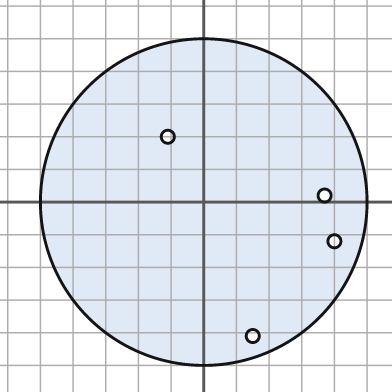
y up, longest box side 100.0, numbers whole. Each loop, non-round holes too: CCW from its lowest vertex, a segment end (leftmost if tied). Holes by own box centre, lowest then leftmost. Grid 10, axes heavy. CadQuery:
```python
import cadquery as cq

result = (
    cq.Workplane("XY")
    .moveTo(0.0, 0.0)
    .circle(50.0)
    .moveTo(15.0, -41.0)
    .circle(2.0)
    .moveTo(40.0, -12.0)
    .circle(2.0)
    .moveTo(37.0, 2.0)
    .circle(2.0)
    .moveTo(-11.0, 20.0)
    .circle(2.0)
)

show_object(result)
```